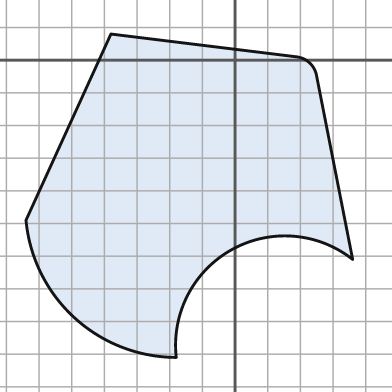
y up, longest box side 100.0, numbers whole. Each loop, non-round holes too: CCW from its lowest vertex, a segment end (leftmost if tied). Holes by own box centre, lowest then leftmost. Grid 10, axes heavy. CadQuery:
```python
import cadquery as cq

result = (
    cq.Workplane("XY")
    .moveTo(-18.0, -91.0)
    .threePointArc((-1.0, -58.0), (36.0, -61.0))
    .lineTo(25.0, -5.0)
    .threePointArc((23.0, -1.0), (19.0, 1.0))
    .lineTo(-38.0, 8.0)
    .lineTo(-64.0, -49.0)
    .threePointArc((-49.0, -79.0), (-18.0, -91.0))
    .close()
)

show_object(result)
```